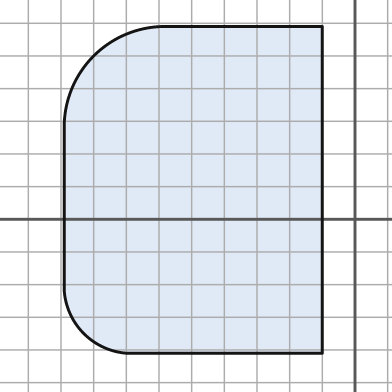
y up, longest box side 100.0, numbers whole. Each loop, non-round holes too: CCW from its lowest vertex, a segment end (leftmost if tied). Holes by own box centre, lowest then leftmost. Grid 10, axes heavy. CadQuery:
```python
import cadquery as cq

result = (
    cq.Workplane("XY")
    .moveTo(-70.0, -41.0)
    .lineTo(-10.0, -41.0)
    .lineTo(-10.0, 59.0)
    .lineTo(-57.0, 59.0)
    .threePointArc((-80.0, 50.0), (-89.0, 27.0))
    .lineTo(-89.0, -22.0)
    .threePointArc((-83.0, -35.0), (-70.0, -41.0))
    .close()
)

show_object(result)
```